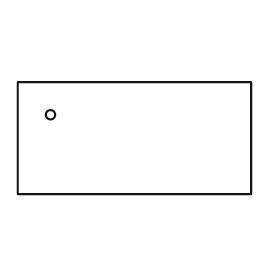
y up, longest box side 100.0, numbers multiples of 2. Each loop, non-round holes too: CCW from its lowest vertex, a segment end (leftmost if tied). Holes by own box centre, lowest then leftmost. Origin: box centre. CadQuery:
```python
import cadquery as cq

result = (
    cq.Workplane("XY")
    .moveTo(-50.0, -24.0)
    .lineTo(50.0, -24.0)
    .lineTo(50.0, 24.0)
    .lineTo(-50.0, 24.0)
    .close()
    .moveTo(-36.0, 10.0)
    .circle(2.0)
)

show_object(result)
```